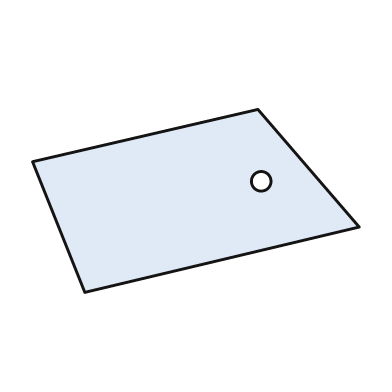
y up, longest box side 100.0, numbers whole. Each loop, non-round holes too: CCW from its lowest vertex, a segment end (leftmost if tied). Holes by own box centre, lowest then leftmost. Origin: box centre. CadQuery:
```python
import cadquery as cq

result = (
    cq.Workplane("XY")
    .moveTo(-34.0, -28.0)
    .lineTo(50.0, -8.0)
    .lineTo(19.0, 28.0)
    .lineTo(-50.0, 12.0)
    .close()
    .moveTo(20.0, 6.0)
    .circle(3.0)
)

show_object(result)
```